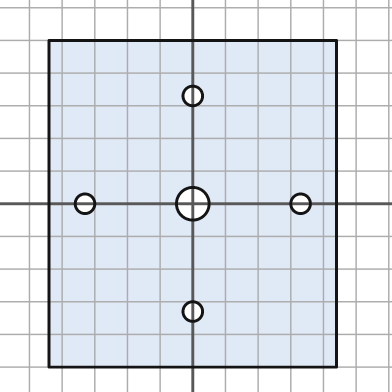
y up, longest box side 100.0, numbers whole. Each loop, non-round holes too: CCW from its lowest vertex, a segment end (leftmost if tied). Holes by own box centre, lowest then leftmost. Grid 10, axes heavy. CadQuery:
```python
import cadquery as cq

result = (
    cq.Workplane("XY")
    .moveTo(-44.0, -50.0)
    .lineTo(44.0, -50.0)
    .lineTo(44.0, 50.0)
    .lineTo(-44.0, 50.0)
    .close()
    .moveTo(0.0, -33.0)
    .circle(3.0)
    .moveTo(-33.0, 0.0)
    .circle(3.0)
    .moveTo(0.0, 0.0)
    .circle(5.0)
    .moveTo(33.0, 0.0)
    .circle(3.0)
    .moveTo(0.0, 33.0)
    .circle(3.0)
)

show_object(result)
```